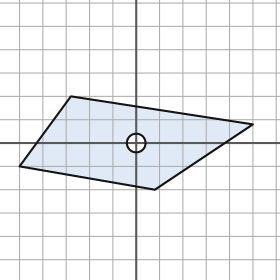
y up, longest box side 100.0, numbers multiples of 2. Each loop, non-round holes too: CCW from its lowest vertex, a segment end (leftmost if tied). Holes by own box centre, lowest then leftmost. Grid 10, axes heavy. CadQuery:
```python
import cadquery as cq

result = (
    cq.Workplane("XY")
    .moveTo(8.0, -20.0)
    .lineTo(50.0, 8.0)
    .lineTo(-28.0, 20.0)
    .lineTo(-50.0, -10.0)
    .close()
    .moveTo(0.0, 0.0)
    .circle(4.0)
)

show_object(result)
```